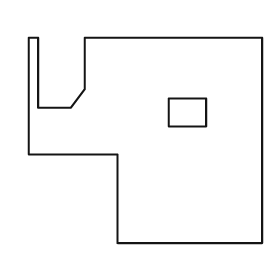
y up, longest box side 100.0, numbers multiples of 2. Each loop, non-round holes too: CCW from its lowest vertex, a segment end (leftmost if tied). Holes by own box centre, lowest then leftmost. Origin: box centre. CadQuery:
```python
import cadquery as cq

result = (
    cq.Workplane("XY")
    .moveTo(-12.0, -44.0)
    .lineTo(50.0, -44.0)
    .lineTo(50.0, 44.0)
    .lineTo(-26.0, 44.0)
    .lineTo(-26.0, 22.0)
    .lineTo(-32.0, 14.0)
    .lineTo(-46.0, 14.0)
    .lineTo(-46.0, 44.0)
    .lineTo(-50.0, 44.0)
    .lineTo(-50.0, -6.0)
    .lineTo(-12.0, -6.0)
    .close()
    .moveTo(10.0, 6.0)
    .lineTo(26.0, 6.0)
    .lineTo(26.0, 18.0)
    .lineTo(10.0, 18.0)
    .close()
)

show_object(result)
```